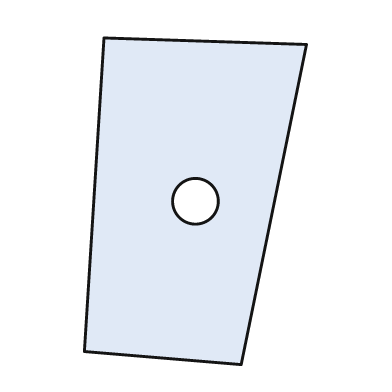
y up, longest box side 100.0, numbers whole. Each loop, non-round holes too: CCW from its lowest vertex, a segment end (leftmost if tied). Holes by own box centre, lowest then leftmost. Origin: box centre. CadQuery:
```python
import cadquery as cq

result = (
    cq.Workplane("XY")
    .moveTo(14.0, -50.0)
    .lineTo(34.0, 48.0)
    .lineTo(-28.0, 50.0)
    .lineTo(-34.0, -46.0)
    .close()
    .moveTo(0.0, 0.0)
    .circle(7.0)
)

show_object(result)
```